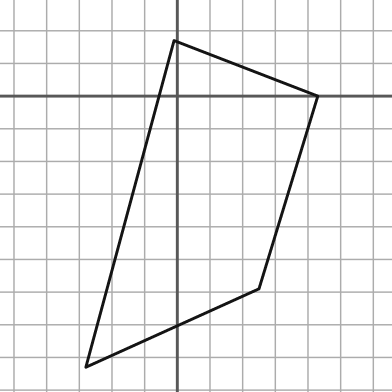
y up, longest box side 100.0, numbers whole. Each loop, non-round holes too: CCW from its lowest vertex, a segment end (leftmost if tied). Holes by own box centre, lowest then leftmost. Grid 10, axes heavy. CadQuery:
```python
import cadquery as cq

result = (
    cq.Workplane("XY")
    .moveTo(-28.0, -83.0)
    .lineTo(25.0, -59.0)
    .lineTo(43.0, 0.0)
    .lineTo(-1.0, 17.0)
    .close()
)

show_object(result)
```